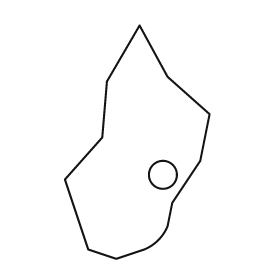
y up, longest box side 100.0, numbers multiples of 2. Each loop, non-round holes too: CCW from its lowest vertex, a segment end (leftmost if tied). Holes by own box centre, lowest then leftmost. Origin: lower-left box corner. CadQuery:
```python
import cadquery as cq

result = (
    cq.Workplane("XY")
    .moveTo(22.0, 0.0)
    .lineTo(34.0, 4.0)
    .threePointArc((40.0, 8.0), (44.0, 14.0))
    .lineTo(46.0, 24.0)
    .lineTo(58.0, 42.0)
    .lineTo(62.0, 62.0)
    .lineTo(44.0, 78.0)
    .lineTo(32.0, 100.0)
    .lineTo(18.0, 76.0)
    .lineTo(16.0, 52.0)
    .lineTo(0.0, 34.0)
    .lineTo(10.0, 4.0)
    .close()
    .moveTo(42.0, 36.0)
    .circle(6.0)
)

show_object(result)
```